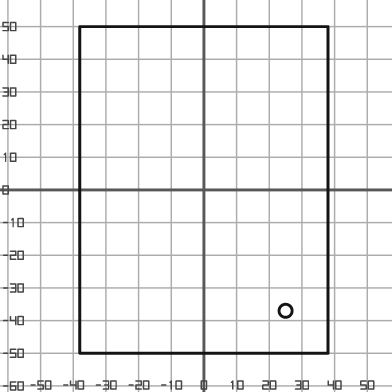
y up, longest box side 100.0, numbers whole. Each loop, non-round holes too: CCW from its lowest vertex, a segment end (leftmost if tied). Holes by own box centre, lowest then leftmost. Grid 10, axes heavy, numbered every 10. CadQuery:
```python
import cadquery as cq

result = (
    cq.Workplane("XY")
    .moveTo(-38.0, -50.0)
    .lineTo(38.0, -50.0)
    .lineTo(38.0, 50.0)
    .lineTo(-38.0, 50.0)
    .close()
    .moveTo(25.0, -37.0)
    .circle(2.0)
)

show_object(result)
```